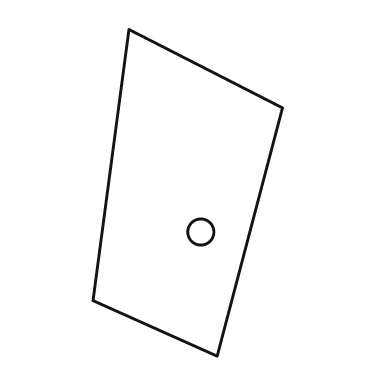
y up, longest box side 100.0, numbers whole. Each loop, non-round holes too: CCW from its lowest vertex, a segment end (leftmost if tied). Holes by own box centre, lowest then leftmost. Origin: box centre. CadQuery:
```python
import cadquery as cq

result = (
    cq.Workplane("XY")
    .moveTo(9.0, -50.0)
    .lineTo(29.0, 26.0)
    .lineTo(-18.0, 50.0)
    .lineTo(-29.0, -33.0)
    .close()
    .moveTo(4.0, -12.0)
    .circle(4.0)
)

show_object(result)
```